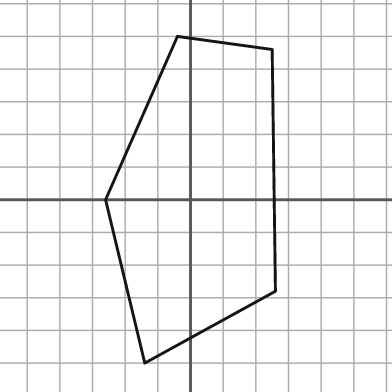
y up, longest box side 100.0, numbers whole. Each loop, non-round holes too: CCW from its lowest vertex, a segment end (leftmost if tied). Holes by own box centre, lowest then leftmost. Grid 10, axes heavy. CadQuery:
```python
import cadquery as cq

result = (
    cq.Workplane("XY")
    .moveTo(-14.0, -50.0)
    .lineTo(26.0, -28.0)
    .lineTo(25.0, 46.0)
    .lineTo(-4.0, 50.0)
    .lineTo(-26.0, 0.0)
    .close()
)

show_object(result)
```